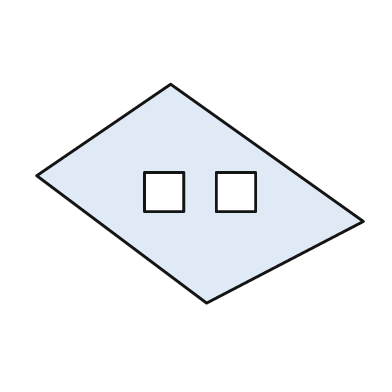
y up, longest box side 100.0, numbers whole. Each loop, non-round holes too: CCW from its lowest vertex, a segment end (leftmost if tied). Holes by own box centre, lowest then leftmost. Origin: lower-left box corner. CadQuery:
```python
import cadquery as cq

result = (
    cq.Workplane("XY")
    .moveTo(52.0, 0.0)
    .lineTo(100.0, 25.0)
    .lineTo(41.0, 67.0)
    .lineTo(0.0, 39.0)
    .close()
    .moveTo(33.0, 28.0)
    .lineTo(45.0, 28.0)
    .lineTo(45.0, 40.0)
    .lineTo(33.0, 40.0)
    .close()
    .moveTo(55.0, 28.0)
    .lineTo(67.0, 28.0)
    .lineTo(67.0, 40.0)
    .lineTo(55.0, 40.0)
    .close()
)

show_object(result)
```